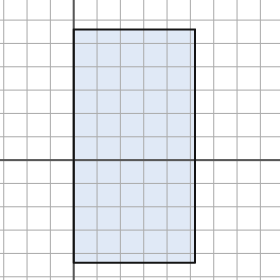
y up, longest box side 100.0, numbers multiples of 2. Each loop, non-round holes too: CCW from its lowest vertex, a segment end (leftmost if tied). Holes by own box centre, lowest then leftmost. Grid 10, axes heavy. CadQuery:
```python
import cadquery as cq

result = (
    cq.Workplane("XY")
    .moveTo(0.0, -44.0)
    .lineTo(52.0, -44.0)
    .lineTo(52.0, 56.0)
    .lineTo(0.0, 56.0)
    .close()
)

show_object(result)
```